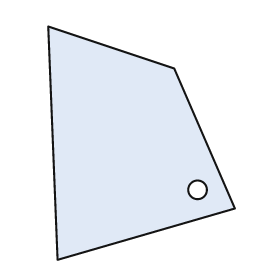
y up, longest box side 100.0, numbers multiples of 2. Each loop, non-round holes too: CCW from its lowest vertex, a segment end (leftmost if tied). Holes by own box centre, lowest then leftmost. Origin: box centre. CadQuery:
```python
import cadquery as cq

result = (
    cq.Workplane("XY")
    .moveTo(-36.0, -50.0)
    .lineTo(40.0, -28.0)
    .lineTo(14.0, 32.0)
    .lineTo(-40.0, 50.0)
    .close()
    .moveTo(24.0, -20.0)
    .circle(4.0)
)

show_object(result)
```